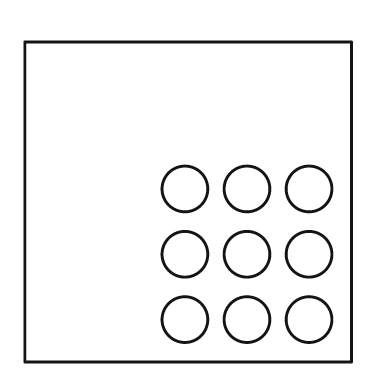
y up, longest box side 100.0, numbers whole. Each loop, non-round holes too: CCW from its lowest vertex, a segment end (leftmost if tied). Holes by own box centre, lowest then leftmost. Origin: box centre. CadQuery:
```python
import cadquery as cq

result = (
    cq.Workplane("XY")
    .moveTo(-50.0, -49.0)
    .lineTo(50.0, -49.0)
    .lineTo(50.0, 49.0)
    .lineTo(-50.0, 49.0)
    .close()
    .moveTo(-1.0, -36.0)
    .circle(7.0)
    .moveTo(18.0, -36.0)
    .circle(7.0)
    .moveTo(37.0, -36.0)
    .circle(7.0)
    .moveTo(-1.0, -16.0)
    .circle(7.0)
    .moveTo(18.0, -16.0)
    .circle(7.0)
    .moveTo(37.0, -16.0)
    .circle(7.0)
    .moveTo(-1.0, 4.0)
    .circle(7.0)
    .moveTo(18.0, 4.0)
    .circle(7.0)
    .moveTo(37.0, 4.0)
    .circle(7.0)
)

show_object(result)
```